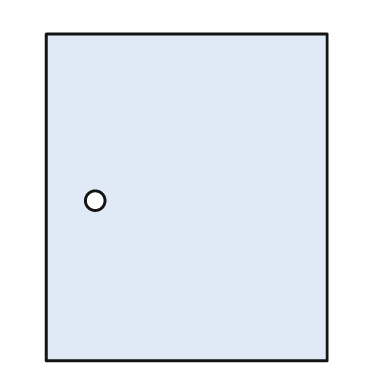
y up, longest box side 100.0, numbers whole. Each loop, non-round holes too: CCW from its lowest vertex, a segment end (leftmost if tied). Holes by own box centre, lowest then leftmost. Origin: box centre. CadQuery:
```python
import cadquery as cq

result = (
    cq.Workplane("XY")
    .moveTo(-43.0, -50.0)
    .lineTo(43.0, -50.0)
    .lineTo(43.0, 50.0)
    .lineTo(-43.0, 50.0)
    .close()
    .moveTo(-28.0, -1.0)
    .circle(3.0)
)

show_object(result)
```